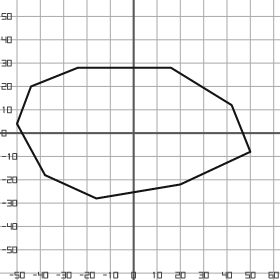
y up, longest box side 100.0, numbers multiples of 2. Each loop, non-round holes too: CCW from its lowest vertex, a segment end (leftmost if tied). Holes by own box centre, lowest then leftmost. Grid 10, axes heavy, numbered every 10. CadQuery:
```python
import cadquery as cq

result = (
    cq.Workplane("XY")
    .moveTo(-16.0, -28.0)
    .lineTo(20.0, -22.0)
    .lineTo(50.0, -8.0)
    .lineTo(42.0, 12.0)
    .lineTo(16.0, 28.0)
    .lineTo(-24.0, 28.0)
    .lineTo(-44.0, 20.0)
    .lineTo(-50.0, 4.0)
    .lineTo(-38.0, -18.0)
    .close()
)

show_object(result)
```